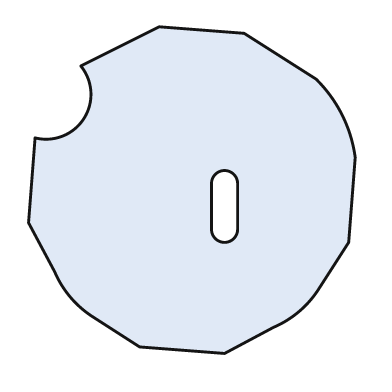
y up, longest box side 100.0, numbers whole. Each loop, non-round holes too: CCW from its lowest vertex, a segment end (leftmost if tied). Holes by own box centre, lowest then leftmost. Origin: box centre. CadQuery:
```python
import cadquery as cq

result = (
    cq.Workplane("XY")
    .moveTo(10.0, -50.0)
    .lineTo(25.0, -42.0)
    .threePointArc((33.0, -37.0), (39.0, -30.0))
    .lineTo(48.0, -16.0)
    .lineTo(50.0, 10.0)
    .threePointArc((46.0, 23.0), (38.0, 34.0))
    .lineTo(16.0, 48.0)
    .lineTo(-10.0, 50.0)
    .lineTo(-34.0, 38.0)
    .threePointArc((-33.0, 22.0), (-48.0, 16.0))
    .lineTo(-50.0, -10.0)
    .lineTo(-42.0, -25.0)
    .threePointArc((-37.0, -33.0), (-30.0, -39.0))
    .lineTo(-16.0, -48.0)
    .close()
    .moveTo(6.0, -12.0)
    .threePointArc((10.0, -16.0), (14.0, -12.0))
    .lineTo(14.0, 2.0)
    .threePointArc((10.0, 6.0), (6.0, 2.0))
    .close()
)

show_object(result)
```